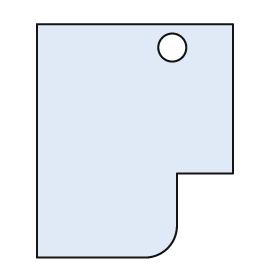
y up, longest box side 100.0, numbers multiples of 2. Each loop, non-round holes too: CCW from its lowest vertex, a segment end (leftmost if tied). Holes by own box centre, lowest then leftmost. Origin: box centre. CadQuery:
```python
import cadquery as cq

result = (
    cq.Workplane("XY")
    .moveTo(-42.0, -50.0)
    .lineTo(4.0, -50.0)
    .threePointArc((14.0, -46.0), (18.0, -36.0))
    .lineTo(18.0, -14.0)
    .lineTo(42.0, -14.0)
    .lineTo(42.0, 50.0)
    .lineTo(-42.0, 50.0)
    .close()
    .moveTo(16.0, 40.0)
    .circle(6.0)
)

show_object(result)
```